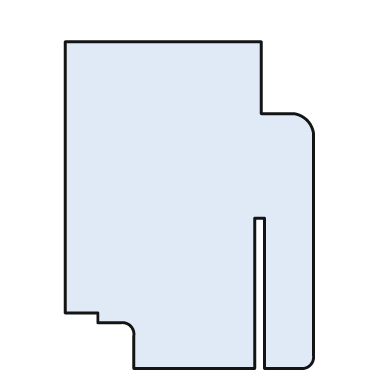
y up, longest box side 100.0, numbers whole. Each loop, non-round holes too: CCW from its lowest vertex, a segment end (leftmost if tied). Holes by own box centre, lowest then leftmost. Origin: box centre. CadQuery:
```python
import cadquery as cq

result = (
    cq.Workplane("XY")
    .moveTo(-17.0, -50.0)
    .lineTo(20.0, -50.0)
    .lineTo(20.0, -4.0)
    .lineTo(23.0, -4.0)
    .lineTo(23.0, -50.0)
    .lineTo(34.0, -50.0)
    .threePointArc((37.0, -49.0), (38.0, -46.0))
    .lineTo(38.0, 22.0)
    .threePointArc((36.0, 26.0), (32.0, 28.0))
    .lineTo(22.0, 28.0)
    .lineTo(22.0, 50.0)
    .lineTo(-38.0, 50.0)
    .lineTo(-38.0, -33.0)
    .lineTo(-28.0, -33.0)
    .lineTo(-28.0, -36.0)
    .lineTo(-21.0, -36.0)
    .threePointArc((-18.0, -37.0), (-17.0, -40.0))
    .close()
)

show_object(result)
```